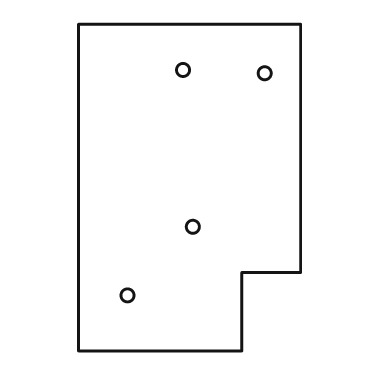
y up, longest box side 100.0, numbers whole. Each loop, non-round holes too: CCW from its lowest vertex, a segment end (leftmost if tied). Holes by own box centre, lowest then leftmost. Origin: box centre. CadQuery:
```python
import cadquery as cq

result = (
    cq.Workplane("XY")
    .moveTo(-34.0, -50.0)
    .lineTo(16.0, -50.0)
    .lineTo(16.0, -26.0)
    .lineTo(34.0, -26.0)
    .lineTo(34.0, 50.0)
    .lineTo(-34.0, 50.0)
    .close()
    .moveTo(-19.0, -33.0)
    .circle(2.0)
    .moveTo(1.0, -12.0)
    .circle(2.0)
    .moveTo(23.0, 35.0)
    .circle(2.0)
    .moveTo(-2.0, 36.0)
    .circle(2.0)
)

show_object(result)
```